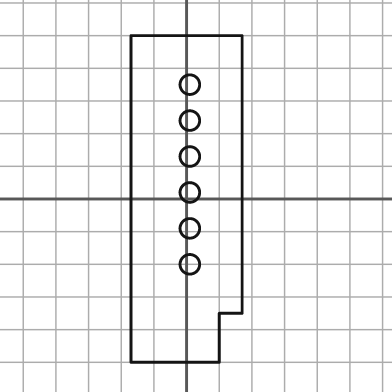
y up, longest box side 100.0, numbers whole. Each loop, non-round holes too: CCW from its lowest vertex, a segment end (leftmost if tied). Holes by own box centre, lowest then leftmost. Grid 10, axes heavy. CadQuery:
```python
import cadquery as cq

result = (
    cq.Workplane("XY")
    .moveTo(-17.0, -50.0)
    .lineTo(10.0, -50.0)
    .lineTo(10.0, -35.0)
    .lineTo(17.0, -35.0)
    .lineTo(17.0, 50.0)
    .lineTo(-17.0, 50.0)
    .close()
    .moveTo(1.0, -20.0)
    .circle(3.0)
    .moveTo(1.0, -9.0)
    .circle(3.0)
    .moveTo(1.0, 2.0)
    .circle(3.0)
    .moveTo(1.0, 13.0)
    .circle(3.0)
    .moveTo(1.0, 24.0)
    .circle(3.0)
    .moveTo(1.0, 35.0)
    .circle(3.0)
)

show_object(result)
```